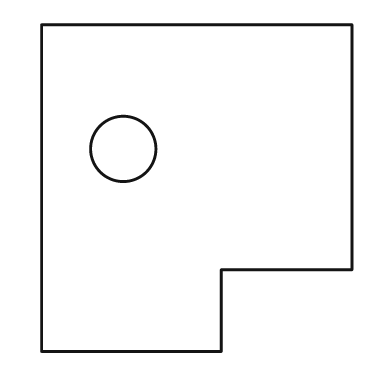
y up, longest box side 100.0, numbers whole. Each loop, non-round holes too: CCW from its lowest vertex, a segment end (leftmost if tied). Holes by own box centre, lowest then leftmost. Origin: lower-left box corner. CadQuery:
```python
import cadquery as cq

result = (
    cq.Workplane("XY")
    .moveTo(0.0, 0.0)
    .lineTo(55.0, 0.0)
    .lineTo(55.0, 25.0)
    .lineTo(95.0, 25.0)
    .lineTo(95.0, 100.0)
    .lineTo(0.0, 100.0)
    .close()
    .moveTo(25.0, 62.0)
    .circle(10.0)
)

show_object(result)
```